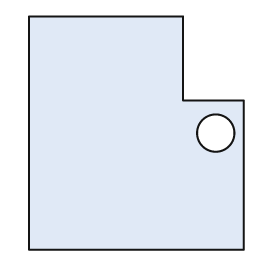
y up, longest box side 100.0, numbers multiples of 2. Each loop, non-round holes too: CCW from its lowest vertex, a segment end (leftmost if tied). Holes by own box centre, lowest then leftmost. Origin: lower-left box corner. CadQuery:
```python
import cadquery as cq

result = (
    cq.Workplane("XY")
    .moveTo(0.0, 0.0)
    .lineTo(92.0, 0.0)
    .lineTo(92.0, 64.0)
    .lineTo(66.0, 64.0)
    .lineTo(66.0, 100.0)
    .lineTo(0.0, 100.0)
    .close()
    .moveTo(80.0, 50.0)
    .circle(8.0)
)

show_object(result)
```